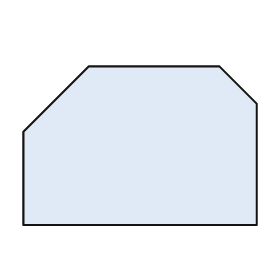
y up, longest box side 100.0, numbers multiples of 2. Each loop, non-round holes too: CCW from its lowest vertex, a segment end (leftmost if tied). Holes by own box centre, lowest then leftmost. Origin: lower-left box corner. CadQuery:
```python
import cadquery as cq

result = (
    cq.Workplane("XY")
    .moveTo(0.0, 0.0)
    .lineTo(100.0, 0.0)
    .lineTo(100.0, 52.0)
    .lineTo(84.0, 68.0)
    .lineTo(28.0, 68.0)
    .lineTo(0.0, 40.0)
    .close()
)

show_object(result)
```